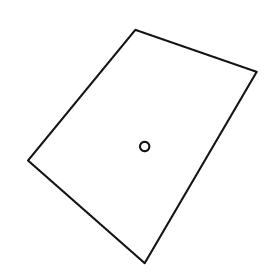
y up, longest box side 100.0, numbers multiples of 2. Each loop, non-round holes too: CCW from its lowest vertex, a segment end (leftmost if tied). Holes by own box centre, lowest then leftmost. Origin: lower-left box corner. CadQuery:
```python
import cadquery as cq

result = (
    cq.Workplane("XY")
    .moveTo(50.0, 0.0)
    .lineTo(98.0, 82.0)
    .lineTo(46.0, 100.0)
    .lineTo(0.0, 44.0)
    .close()
    .moveTo(50.0, 50.0)
    .circle(2.0)
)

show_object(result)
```